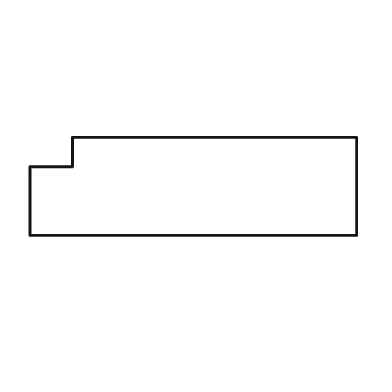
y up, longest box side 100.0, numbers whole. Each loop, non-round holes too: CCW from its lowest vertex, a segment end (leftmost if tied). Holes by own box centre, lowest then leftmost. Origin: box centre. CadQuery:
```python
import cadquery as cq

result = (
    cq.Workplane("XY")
    .moveTo(-50.0, -15.0)
    .lineTo(50.0, -15.0)
    .lineTo(50.0, 15.0)
    .lineTo(-37.0, 15.0)
    .lineTo(-37.0, 6.0)
    .lineTo(-50.0, 6.0)
    .close()
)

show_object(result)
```